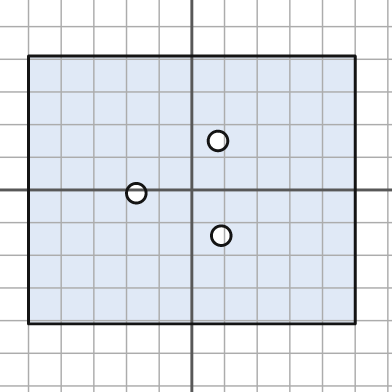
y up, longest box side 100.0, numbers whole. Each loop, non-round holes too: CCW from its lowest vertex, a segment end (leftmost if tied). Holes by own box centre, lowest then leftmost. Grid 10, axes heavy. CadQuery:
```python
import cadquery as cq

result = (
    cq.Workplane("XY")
    .moveTo(-50.0, -41.0)
    .lineTo(50.0, -41.0)
    .lineTo(50.0, 41.0)
    .lineTo(-50.0, 41.0)
    .close()
    .moveTo(9.0, -14.0)
    .circle(3.0)
    .moveTo(-17.0, -1.0)
    .circle(3.0)
    .moveTo(8.0, 15.0)
    .circle(3.0)
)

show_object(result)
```